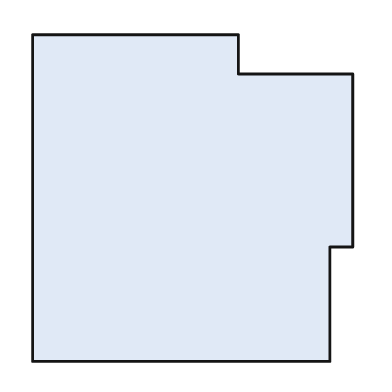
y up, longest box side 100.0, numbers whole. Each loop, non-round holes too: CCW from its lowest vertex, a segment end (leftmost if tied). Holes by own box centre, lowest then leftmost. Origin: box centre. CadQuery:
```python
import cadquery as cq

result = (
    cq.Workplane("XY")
    .moveTo(-49.0, -50.0)
    .lineTo(42.0, -50.0)
    .lineTo(42.0, -15.0)
    .lineTo(49.0, -15.0)
    .lineTo(49.0, 38.0)
    .lineTo(14.0, 38.0)
    .lineTo(14.0, 50.0)
    .lineTo(-49.0, 50.0)
    .close()
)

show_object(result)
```